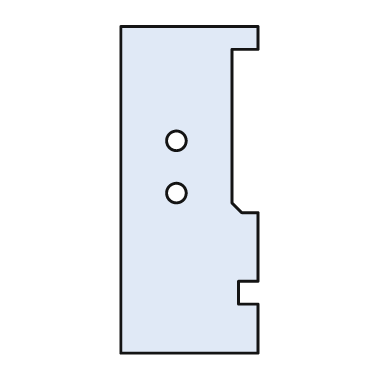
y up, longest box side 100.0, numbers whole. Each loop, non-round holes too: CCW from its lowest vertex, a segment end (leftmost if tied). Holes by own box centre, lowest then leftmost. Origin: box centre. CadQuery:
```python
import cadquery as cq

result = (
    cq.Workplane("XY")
    .moveTo(-21.0, -50.0)
    .lineTo(21.0, -50.0)
    .lineTo(21.0, -35.0)
    .lineTo(15.0, -35.0)
    .lineTo(15.0, -28.0)
    .lineTo(21.0, -28.0)
    .lineTo(21.0, -7.0)
    .lineTo(16.0, -7.0)
    .lineTo(13.0, -4.0)
    .lineTo(13.0, 43.0)
    .lineTo(21.0, 43.0)
    .lineTo(21.0, 50.0)
    .lineTo(-21.0, 50.0)
    .close()
    .moveTo(-4.0, -1.0)
    .circle(3.0)
    .moveTo(-4.0, 15.0)
    .circle(3.0)
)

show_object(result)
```